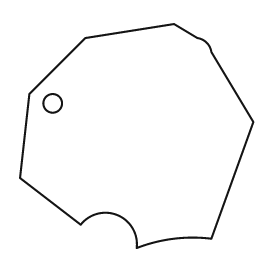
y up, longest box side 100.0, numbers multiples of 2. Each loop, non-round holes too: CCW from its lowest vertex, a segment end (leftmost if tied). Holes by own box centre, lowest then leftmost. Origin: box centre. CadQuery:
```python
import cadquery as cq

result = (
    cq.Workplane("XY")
    .moveTo(0.0, -48.0)
    .threePointArc((16.0, -44.0), (32.0, -44.0))
    .lineTo(50.0, 6.0)
    .lineTo(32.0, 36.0)
    .threePointArc((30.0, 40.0), (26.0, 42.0))
    .lineTo(16.0, 48.0)
    .lineTo(-22.0, 42.0)
    .lineTo(-46.0, 18.0)
    .lineTo(-50.0, -18.0)
    .lineTo(-24.0, -38.0)
    .threePointArc((-8.0, -34.0), (0.0, -48.0))
    .close()
    .moveTo(-36.0, 14.0)
    .circle(4.0)
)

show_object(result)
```